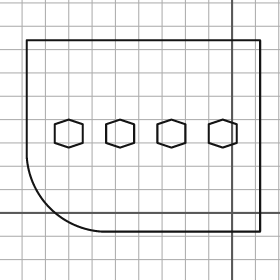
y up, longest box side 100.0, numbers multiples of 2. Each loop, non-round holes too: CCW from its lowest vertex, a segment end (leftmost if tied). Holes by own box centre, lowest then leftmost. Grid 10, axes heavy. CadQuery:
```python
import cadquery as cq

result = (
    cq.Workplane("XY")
    .moveTo(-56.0, -8.0)
    .lineTo(12.0, -8.0)
    .lineTo(12.0, 74.0)
    .lineTo(-88.0, 74.0)
    .lineTo(-88.0, 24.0)
    .threePointArc((-78.0, 2.0), (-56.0, -8.0))
    .close()
    .moveTo(-70.0, 28.0)
    .lineTo(-64.0, 30.0)
    .lineTo(-64.0, 38.0)
    .lineTo(-70.0, 40.0)
    .lineTo(-76.0, 38.0)
    .lineTo(-76.0, 30.0)
    .close()
    .moveTo(-48.0, 28.0)
    .lineTo(-42.0, 30.0)
    .lineTo(-42.0, 38.0)
    .lineTo(-48.0, 40.0)
    .lineTo(-54.0, 38.0)
    .lineTo(-54.0, 30.0)
    .close()
    .moveTo(-26.0, 28.0)
    .lineTo(-20.0, 30.0)
    .lineTo(-20.0, 38.0)
    .lineTo(-26.0, 40.0)
    .lineTo(-32.0, 38.0)
    .lineTo(-32.0, 30.0)
    .close()
    .moveTo(-4.0, 28.0)
    .lineTo(2.0, 30.0)
    .lineTo(2.0, 38.0)
    .lineTo(-4.0, 40.0)
    .lineTo(-10.0, 38.0)
    .lineTo(-10.0, 30.0)
    .close()
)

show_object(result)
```